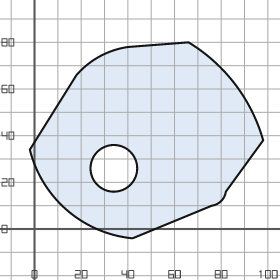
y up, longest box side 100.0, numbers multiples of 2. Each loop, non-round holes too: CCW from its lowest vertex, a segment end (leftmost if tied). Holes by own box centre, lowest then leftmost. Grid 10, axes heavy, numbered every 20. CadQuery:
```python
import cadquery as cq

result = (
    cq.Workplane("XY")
    .moveTo(42.0, -4.0)
    .lineTo(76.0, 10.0)
    .threePointArc((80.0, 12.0), (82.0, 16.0))
    .lineTo(98.0, 38.0)
    .threePointArc((86.0, 62.0), (66.0, 80.0))
    .lineTo(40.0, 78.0)
    .threePointArc((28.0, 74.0), (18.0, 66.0))
    .lineTo(-2.0, 34.0)
    .threePointArc((14.0, 8.0), (42.0, -4.0))
    .close()
    .moveTo(34.0, 26.0)
    .circle(10.0)
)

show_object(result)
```